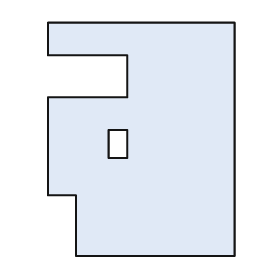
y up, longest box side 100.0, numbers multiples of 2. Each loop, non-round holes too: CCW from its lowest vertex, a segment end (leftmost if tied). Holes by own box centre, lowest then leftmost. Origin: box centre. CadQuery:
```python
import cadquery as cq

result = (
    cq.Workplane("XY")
    .moveTo(-28.0, -50.0)
    .lineTo(40.0, -50.0)
    .lineTo(40.0, 50.0)
    .lineTo(-40.0, 50.0)
    .lineTo(-40.0, 36.0)
    .lineTo(-6.0, 36.0)
    .lineTo(-6.0, 18.0)
    .lineTo(-40.0, 18.0)
    .lineTo(-40.0, -24.0)
    .lineTo(-28.0, -24.0)
    .close()
    .moveTo(-14.0, -8.0)
    .lineTo(-6.0, -8.0)
    .lineTo(-6.0, 4.0)
    .lineTo(-14.0, 4.0)
    .close()
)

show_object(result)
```